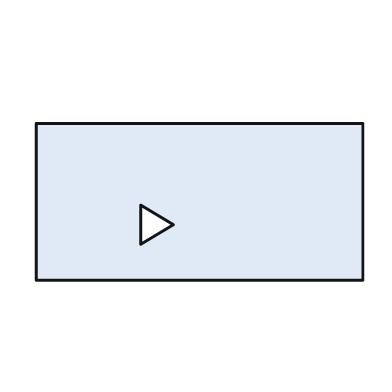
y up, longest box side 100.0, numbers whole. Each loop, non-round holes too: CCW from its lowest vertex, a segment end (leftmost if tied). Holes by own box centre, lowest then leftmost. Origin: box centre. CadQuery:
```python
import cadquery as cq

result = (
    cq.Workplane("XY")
    .moveTo(-50.0, -24.0)
    .lineTo(50.0, -24.0)
    .lineTo(50.0, 24.0)
    .lineTo(-50.0, 24.0)
    .close()
    .moveTo(-18.0, -13.0)
    .lineTo(-8.0, -7.0)
    .lineTo(-18.0, -1.0)
    .close()
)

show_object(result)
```